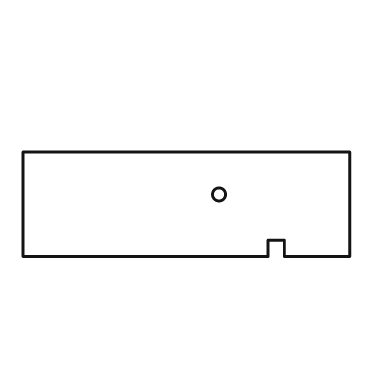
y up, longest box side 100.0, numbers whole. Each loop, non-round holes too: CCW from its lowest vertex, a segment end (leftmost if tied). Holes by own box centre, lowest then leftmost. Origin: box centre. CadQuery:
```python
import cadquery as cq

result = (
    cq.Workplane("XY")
    .moveTo(-50.0, -16.0)
    .lineTo(25.0, -16.0)
    .lineTo(25.0, -11.0)
    .lineTo(30.0, -11.0)
    .lineTo(30.0, -16.0)
    .lineTo(50.0, -16.0)
    .lineTo(50.0, 16.0)
    .lineTo(-50.0, 16.0)
    .close()
    .moveTo(10.0, 3.0)
    .circle(2.0)
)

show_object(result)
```